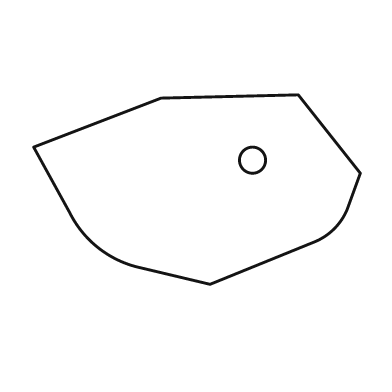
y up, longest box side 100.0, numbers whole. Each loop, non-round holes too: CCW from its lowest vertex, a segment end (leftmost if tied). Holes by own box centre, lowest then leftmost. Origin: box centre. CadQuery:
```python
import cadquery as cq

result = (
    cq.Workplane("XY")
    .moveTo(4.0, -29.0)
    .lineTo(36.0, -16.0)
    .threePointArc((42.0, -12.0), (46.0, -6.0))
    .lineTo(50.0, 5.0)
    .lineTo(31.0, 29.0)
    .lineTo(-11.0, 28.0)
    .lineTo(-50.0, 13.0)
    .lineTo(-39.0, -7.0)
    .threePointArc((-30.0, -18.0), (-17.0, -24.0))
    .close()
    .moveTo(17.0, 9.0)
    .circle(4.0)
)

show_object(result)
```